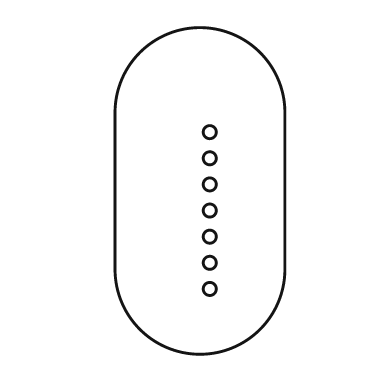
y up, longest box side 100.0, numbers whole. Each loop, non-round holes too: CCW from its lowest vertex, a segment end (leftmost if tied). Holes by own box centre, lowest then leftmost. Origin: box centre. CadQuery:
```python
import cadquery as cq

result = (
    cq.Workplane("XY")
    .moveTo(-26.0, -24.0)
    .threePointArc((0.0, -50.0), (26.0, -24.0))
    .lineTo(26.0, 24.0)
    .threePointArc((0.0, 50.0), (-26.0, 24.0))
    .close()
    .moveTo(3.0, -30.0)
    .circle(2.0)
    .moveTo(3.0, -22.0)
    .circle(2.0)
    .moveTo(3.0, -14.0)
    .circle(2.0)
    .moveTo(3.0, -6.0)
    .circle(2.0)
    .moveTo(3.0, 2.0)
    .circle(2.0)
    .moveTo(3.0, 10.0)
    .circle(2.0)
    .moveTo(3.0, 18.0)
    .circle(2.0)
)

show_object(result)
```